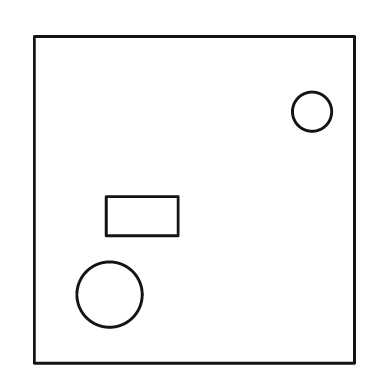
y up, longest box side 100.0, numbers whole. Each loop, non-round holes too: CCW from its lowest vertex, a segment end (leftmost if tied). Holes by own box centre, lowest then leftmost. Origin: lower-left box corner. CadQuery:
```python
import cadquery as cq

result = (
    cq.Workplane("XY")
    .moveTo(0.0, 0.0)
    .lineTo(98.0, 0.0)
    .lineTo(98.0, 100.0)
    .lineTo(0.0, 100.0)
    .close()
    .moveTo(23.0, 21.0)
    .circle(10.0)
    .moveTo(22.0, 39.0)
    .lineTo(44.0, 39.0)
    .lineTo(44.0, 51.0)
    .lineTo(22.0, 51.0)
    .close()
    .moveTo(85.0, 77.0)
    .circle(6.0)
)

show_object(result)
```